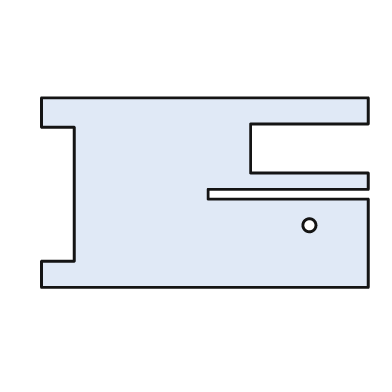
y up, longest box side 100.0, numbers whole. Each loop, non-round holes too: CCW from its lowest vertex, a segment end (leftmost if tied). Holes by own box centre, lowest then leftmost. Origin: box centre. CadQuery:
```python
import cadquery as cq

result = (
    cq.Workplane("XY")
    .moveTo(-50.0, -29.0)
    .lineTo(50.0, -29.0)
    .lineTo(50.0, -2.0)
    .lineTo(1.0, -2.0)
    .lineTo(1.0, 1.0)
    .lineTo(50.0, 1.0)
    .lineTo(50.0, 6.0)
    .lineTo(14.0, 6.0)
    .lineTo(14.0, 21.0)
    .lineTo(50.0, 21.0)
    .lineTo(50.0, 29.0)
    .lineTo(-50.0, 29.0)
    .lineTo(-50.0, 20.0)
    .lineTo(-40.0, 20.0)
    .lineTo(-40.0, -21.0)
    .lineTo(-50.0, -21.0)
    .close()
    .moveTo(32.0, -10.0)
    .circle(2.0)
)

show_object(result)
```